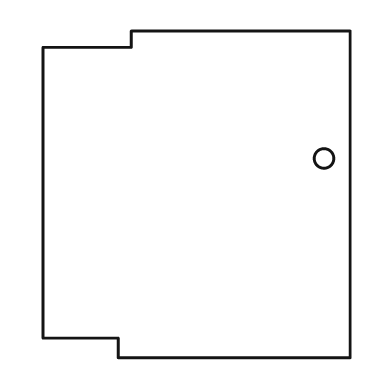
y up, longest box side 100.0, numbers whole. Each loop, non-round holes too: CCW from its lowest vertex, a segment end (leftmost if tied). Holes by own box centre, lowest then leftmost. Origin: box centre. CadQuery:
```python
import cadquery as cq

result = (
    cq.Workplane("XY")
    .moveTo(-24.0, -50.0)
    .lineTo(47.0, -50.0)
    .lineTo(47.0, 50.0)
    .lineTo(-20.0, 50.0)
    .lineTo(-20.0, 45.0)
    .lineTo(-47.0, 45.0)
    .lineTo(-47.0, -44.0)
    .lineTo(-24.0, -44.0)
    .close()
    .moveTo(39.0, 11.0)
    .circle(3.0)
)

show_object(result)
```